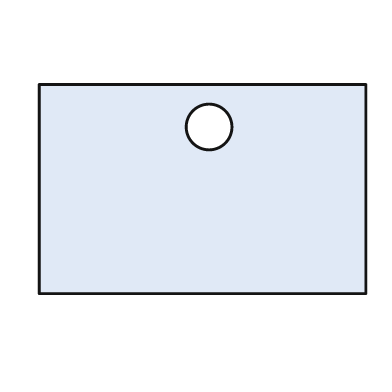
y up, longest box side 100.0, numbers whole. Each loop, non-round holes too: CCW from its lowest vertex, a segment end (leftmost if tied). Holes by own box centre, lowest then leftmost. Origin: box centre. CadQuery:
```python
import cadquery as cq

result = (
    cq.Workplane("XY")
    .moveTo(-50.0, -32.0)
    .lineTo(50.0, -32.0)
    .lineTo(50.0, 32.0)
    .lineTo(-50.0, 32.0)
    .close()
    .moveTo(2.0, 19.0)
    .circle(7.0)
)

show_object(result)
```